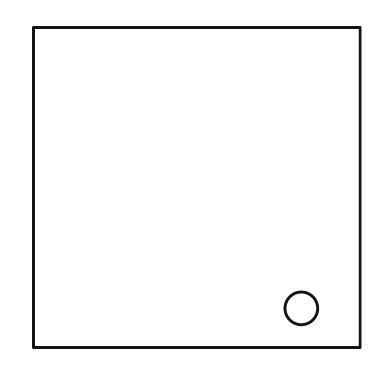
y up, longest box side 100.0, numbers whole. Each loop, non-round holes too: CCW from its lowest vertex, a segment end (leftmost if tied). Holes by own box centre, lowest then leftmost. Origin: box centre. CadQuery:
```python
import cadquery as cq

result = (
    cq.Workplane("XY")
    .moveTo(-50.0, -49.0)
    .lineTo(50.0, -49.0)
    .lineTo(50.0, 49.0)
    .lineTo(-50.0, 49.0)
    .close()
    .moveTo(32.0, -37.0)
    .circle(5.0)
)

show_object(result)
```